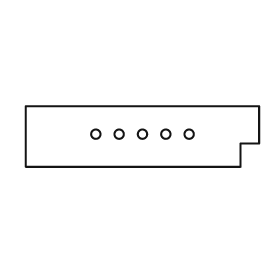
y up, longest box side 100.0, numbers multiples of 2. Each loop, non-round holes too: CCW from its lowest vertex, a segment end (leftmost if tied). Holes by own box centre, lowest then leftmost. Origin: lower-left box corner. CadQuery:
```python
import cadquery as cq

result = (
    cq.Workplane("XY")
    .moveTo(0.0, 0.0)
    .lineTo(92.0, 0.0)
    .lineTo(92.0, 10.0)
    .lineTo(100.0, 10.0)
    .lineTo(100.0, 26.0)
    .lineTo(0.0, 26.0)
    .close()
    .moveTo(30.0, 14.0)
    .circle(2.0)
    .moveTo(40.0, 14.0)
    .circle(2.0)
    .moveTo(50.0, 14.0)
    .circle(2.0)
    .moveTo(60.0, 14.0)
    .circle(2.0)
    .moveTo(70.0, 14.0)
    .circle(2.0)
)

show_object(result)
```